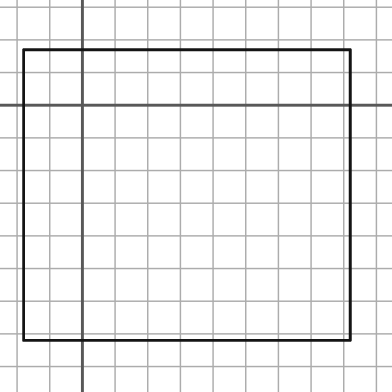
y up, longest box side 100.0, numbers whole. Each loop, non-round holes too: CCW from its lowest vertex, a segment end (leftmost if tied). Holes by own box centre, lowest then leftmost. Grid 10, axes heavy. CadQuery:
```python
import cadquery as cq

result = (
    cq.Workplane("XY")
    .moveTo(-18.0, -72.0)
    .lineTo(82.0, -72.0)
    .lineTo(82.0, 17.0)
    .lineTo(-18.0, 17.0)
    .close()
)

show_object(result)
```